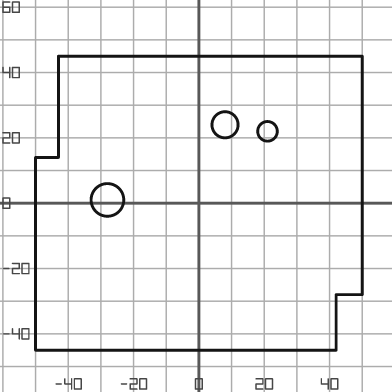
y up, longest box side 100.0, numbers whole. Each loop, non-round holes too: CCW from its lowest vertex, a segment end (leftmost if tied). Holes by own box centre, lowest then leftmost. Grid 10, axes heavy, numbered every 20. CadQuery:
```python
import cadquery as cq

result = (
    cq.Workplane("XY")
    .moveTo(-50.0, -45.0)
    .lineTo(42.0, -45.0)
    .lineTo(42.0, -28.0)
    .lineTo(50.0, -28.0)
    .lineTo(50.0, 45.0)
    .lineTo(-43.0, 45.0)
    .lineTo(-43.0, 14.0)
    .lineTo(-50.0, 14.0)
    .close()
    .moveTo(-28.0, 1.0)
    .circle(5.0)
    .moveTo(21.0, 22.0)
    .circle(3.0)
    .moveTo(8.0, 24.0)
    .circle(4.0)
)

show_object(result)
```